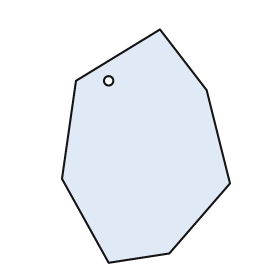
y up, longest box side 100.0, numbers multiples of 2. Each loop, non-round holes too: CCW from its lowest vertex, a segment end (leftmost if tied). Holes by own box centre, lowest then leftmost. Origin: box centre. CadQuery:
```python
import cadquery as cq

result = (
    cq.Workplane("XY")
    .moveTo(-16.0, -50.0)
    .lineTo(10.0, -46.0)
    .lineTo(36.0, -16.0)
    .lineTo(26.0, 24.0)
    .lineTo(6.0, 50.0)
    .lineTo(-30.0, 28.0)
    .lineTo(-36.0, -14.0)
    .close()
    .moveTo(-16.0, 28.0)
    .circle(2.0)
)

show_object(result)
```